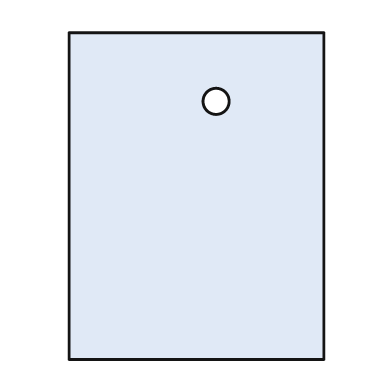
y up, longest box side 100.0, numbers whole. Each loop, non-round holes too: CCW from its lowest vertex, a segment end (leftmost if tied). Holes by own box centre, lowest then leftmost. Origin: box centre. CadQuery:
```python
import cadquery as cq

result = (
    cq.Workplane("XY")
    .moveTo(-39.0, -50.0)
    .lineTo(39.0, -50.0)
    .lineTo(39.0, 50.0)
    .lineTo(-39.0, 50.0)
    .close()
    .moveTo(6.0, 29.0)
    .circle(4.0)
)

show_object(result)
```